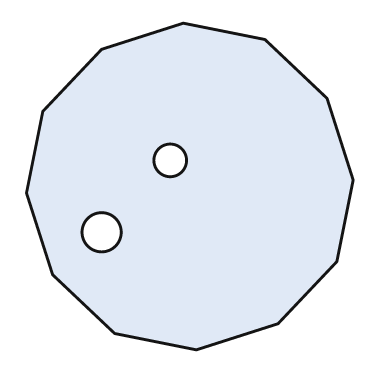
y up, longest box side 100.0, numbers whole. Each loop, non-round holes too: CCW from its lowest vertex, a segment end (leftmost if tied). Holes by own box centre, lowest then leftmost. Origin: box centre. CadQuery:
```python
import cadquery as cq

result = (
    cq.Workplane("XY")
    .moveTo(2.0, -50.0)
    .lineTo(27.0, -42.0)
    .lineTo(45.0, -23.0)
    .lineTo(50.0, 2.0)
    .lineTo(42.0, 27.0)
    .lineTo(23.0, 45.0)
    .lineTo(-2.0, 50.0)
    .lineTo(-27.0, 42.0)
    .lineTo(-45.0, 23.0)
    .lineTo(-50.0, -2.0)
    .lineTo(-42.0, -27.0)
    .lineTo(-23.0, -45.0)
    .close()
    .moveTo(-27.0, -14.0)
    .circle(6.0)
    .moveTo(-6.0, 8.0)
    .circle(5.0)
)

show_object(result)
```